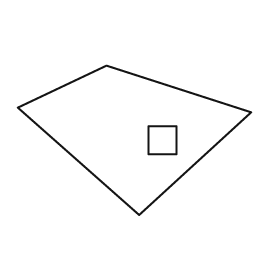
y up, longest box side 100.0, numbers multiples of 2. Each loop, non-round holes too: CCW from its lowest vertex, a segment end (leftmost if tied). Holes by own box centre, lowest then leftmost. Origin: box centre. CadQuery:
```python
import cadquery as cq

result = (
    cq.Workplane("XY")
    .moveTo(2.0, -32.0)
    .lineTo(50.0, 12.0)
    .lineTo(-12.0, 32.0)
    .lineTo(-50.0, 14.0)
    .close()
    .moveTo(6.0, -6.0)
    .lineTo(18.0, -6.0)
    .lineTo(18.0, 6.0)
    .lineTo(6.0, 6.0)
    .close()
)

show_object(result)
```